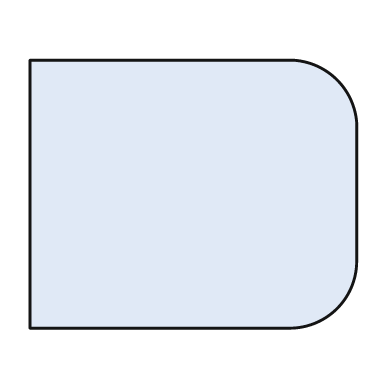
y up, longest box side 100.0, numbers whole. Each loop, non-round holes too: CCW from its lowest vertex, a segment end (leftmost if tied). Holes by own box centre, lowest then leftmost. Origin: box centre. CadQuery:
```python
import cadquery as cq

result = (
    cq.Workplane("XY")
    .moveTo(-50.0, -41.0)
    .lineTo(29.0, -41.0)
    .threePointArc((44.0, -35.0), (50.0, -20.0))
    .lineTo(50.0, 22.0)
    .threePointArc((44.0, 35.0), (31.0, 41.0))
    .lineTo(-50.0, 41.0)
    .close()
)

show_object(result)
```